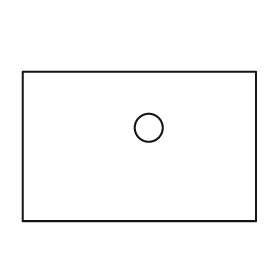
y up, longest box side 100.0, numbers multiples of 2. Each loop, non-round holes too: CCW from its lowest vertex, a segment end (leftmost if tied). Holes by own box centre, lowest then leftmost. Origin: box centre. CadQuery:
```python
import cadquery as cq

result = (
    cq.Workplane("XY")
    .moveTo(-50.0, -32.0)
    .lineTo(50.0, -32.0)
    .lineTo(50.0, 32.0)
    .lineTo(-50.0, 32.0)
    .close()
    .moveTo(4.0, 8.0)
    .circle(6.0)
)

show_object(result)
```